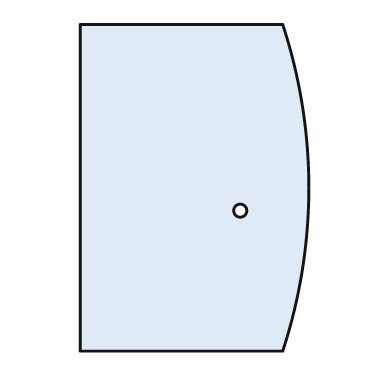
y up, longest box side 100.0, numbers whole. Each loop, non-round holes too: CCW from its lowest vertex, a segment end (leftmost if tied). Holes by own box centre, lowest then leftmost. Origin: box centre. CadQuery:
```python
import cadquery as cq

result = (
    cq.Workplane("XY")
    .moveTo(-35.0, -50.0)
    .lineTo(27.0, -50.0)
    .threePointArc((35.0, 0.0), (27.0, 50.0))
    .lineTo(-35.0, 50.0)
    .close()
    .moveTo(14.0, -7.0)
    .circle(2.0)
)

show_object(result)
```